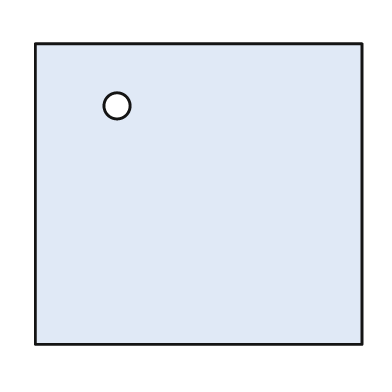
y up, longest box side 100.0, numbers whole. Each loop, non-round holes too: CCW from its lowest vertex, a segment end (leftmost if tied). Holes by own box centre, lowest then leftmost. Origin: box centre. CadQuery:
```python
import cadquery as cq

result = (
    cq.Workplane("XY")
    .moveTo(-50.0, -46.0)
    .lineTo(50.0, -46.0)
    .lineTo(50.0, 46.0)
    .lineTo(-50.0, 46.0)
    .close()
    .moveTo(-25.0, 27.0)
    .circle(4.0)
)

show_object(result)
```